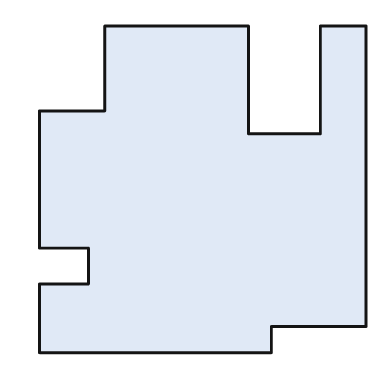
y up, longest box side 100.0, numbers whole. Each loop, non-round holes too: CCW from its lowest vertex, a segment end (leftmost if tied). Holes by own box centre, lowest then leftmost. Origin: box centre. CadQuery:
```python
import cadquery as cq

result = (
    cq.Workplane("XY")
    .moveTo(-50.0, -50.0)
    .lineTo(21.0, -50.0)
    .lineTo(21.0, -42.0)
    .lineTo(50.0, -42.0)
    .lineTo(50.0, 50.0)
    .lineTo(36.0, 50.0)
    .lineTo(36.0, 17.0)
    .lineTo(14.0, 17.0)
    .lineTo(14.0, 50.0)
    .lineTo(-30.0, 50.0)
    .lineTo(-30.0, 24.0)
    .lineTo(-50.0, 24.0)
    .lineTo(-50.0, -18.0)
    .lineTo(-35.0, -18.0)
    .lineTo(-35.0, -29.0)
    .lineTo(-50.0, -29.0)
    .close()
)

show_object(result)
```